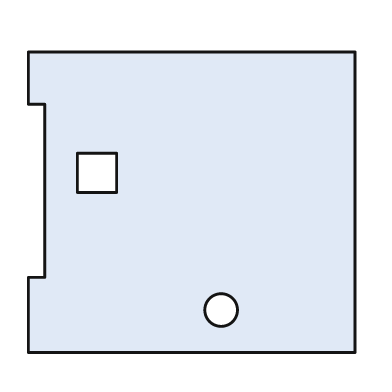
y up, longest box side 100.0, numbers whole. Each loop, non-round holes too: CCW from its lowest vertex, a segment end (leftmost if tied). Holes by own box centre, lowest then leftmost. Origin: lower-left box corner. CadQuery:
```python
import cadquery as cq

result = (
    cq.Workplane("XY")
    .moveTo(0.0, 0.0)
    .lineTo(100.0, 0.0)
    .lineTo(100.0, 92.0)
    .lineTo(0.0, 92.0)
    .lineTo(0.0, 76.0)
    .lineTo(5.0, 76.0)
    .lineTo(5.0, 23.0)
    .lineTo(0.0, 23.0)
    .close()
    .moveTo(59.0, 13.0)
    .circle(5.0)
    .moveTo(15.0, 49.0)
    .lineTo(27.0, 49.0)
    .lineTo(27.0, 61.0)
    .lineTo(15.0, 61.0)
    .close()
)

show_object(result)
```